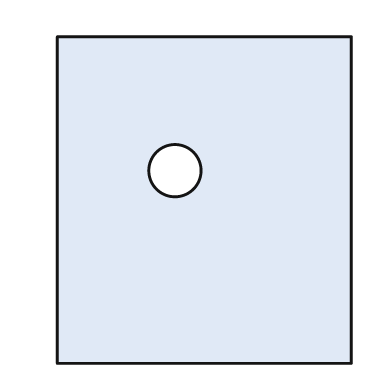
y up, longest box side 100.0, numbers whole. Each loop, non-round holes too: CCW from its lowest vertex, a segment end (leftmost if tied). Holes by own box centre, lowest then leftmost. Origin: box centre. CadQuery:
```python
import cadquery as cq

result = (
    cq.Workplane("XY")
    .moveTo(-45.0, -50.0)
    .lineTo(45.0, -50.0)
    .lineTo(45.0, 50.0)
    .lineTo(-45.0, 50.0)
    .close()
    .moveTo(-9.0, 9.0)
    .circle(8.0)
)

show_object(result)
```